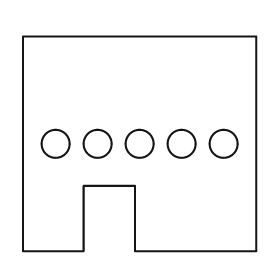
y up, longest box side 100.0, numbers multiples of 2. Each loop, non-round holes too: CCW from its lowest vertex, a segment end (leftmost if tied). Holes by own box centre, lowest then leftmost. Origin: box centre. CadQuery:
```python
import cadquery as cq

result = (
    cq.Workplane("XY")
    .moveTo(-50.0, -46.0)
    .lineTo(-24.0, -46.0)
    .lineTo(-24.0, -18.0)
    .lineTo(-2.0, -18.0)
    .lineTo(-2.0, -46.0)
    .lineTo(50.0, -46.0)
    .lineTo(50.0, 46.0)
    .lineTo(-50.0, 46.0)
    .close()
    .moveTo(-36.0, 0.0)
    .circle(6.0)
    .moveTo(-18.0, 0.0)
    .circle(6.0)
    .moveTo(0.0, 0.0)
    .circle(6.0)
    .moveTo(18.0, 0.0)
    .circle(6.0)
    .moveTo(36.0, 0.0)
    .circle(6.0)
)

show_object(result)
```